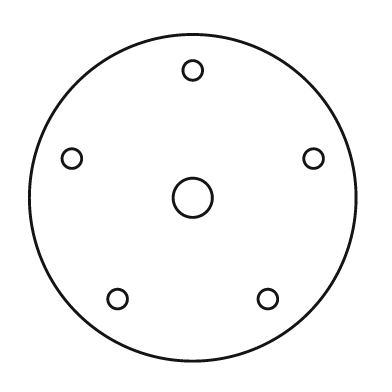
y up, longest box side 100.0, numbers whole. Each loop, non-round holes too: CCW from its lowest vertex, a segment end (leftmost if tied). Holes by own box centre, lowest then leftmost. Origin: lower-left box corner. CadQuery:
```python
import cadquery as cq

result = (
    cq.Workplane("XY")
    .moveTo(50.0, 50.0)
    .circle(50.0)
    .moveTo(27.0, 19.0)
    .circle(3.0)
    .moveTo(73.0, 19.0)
    .circle(3.0)
    .moveTo(50.0, 50.0)
    .circle(6.0)
    .moveTo(13.0, 62.0)
    .circle(3.0)
    .moveTo(87.0, 62.0)
    .circle(3.0)
    .moveTo(50.0, 89.0)
    .circle(3.0)
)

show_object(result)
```